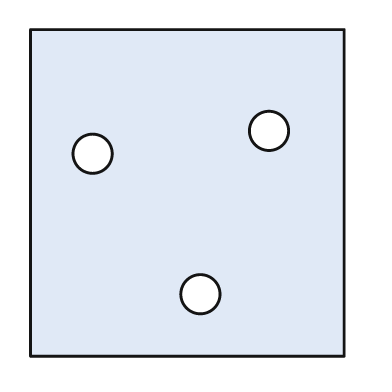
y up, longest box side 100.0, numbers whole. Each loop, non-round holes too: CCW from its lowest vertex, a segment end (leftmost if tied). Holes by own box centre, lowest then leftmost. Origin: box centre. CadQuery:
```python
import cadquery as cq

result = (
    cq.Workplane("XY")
    .moveTo(-48.0, -50.0)
    .lineTo(48.0, -50.0)
    .lineTo(48.0, 50.0)
    .lineTo(-48.0, 50.0)
    .close()
    .moveTo(4.0, -31.0)
    .circle(6.0)
    .moveTo(-29.0, 12.0)
    .circle(6.0)
    .moveTo(25.0, 19.0)
    .circle(6.0)
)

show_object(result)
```